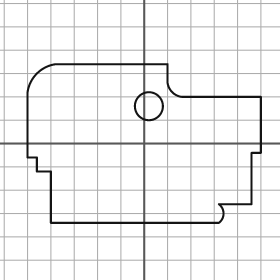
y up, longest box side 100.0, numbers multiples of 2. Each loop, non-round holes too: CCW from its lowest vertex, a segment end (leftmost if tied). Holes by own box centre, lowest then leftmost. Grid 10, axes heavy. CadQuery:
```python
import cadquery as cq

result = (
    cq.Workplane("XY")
    .moveTo(-40.0, -34.0)
    .lineTo(32.0, -34.0)
    .threePointArc((34.0, -30.0), (32.0, -26.0))
    .lineTo(46.0, -26.0)
    .lineTo(46.0, -4.0)
    .lineTo(50.0, -4.0)
    .lineTo(50.0, 20.0)
    .lineTo(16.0, 20.0)
    .threePointArc((12.0, 22.0), (10.0, 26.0))
    .lineTo(10.0, 34.0)
    .lineTo(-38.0, 34.0)
    .threePointArc((-46.0, 30.0), (-50.0, 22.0))
    .lineTo(-50.0, -6.0)
    .lineTo(-46.0, -6.0)
    .lineTo(-46.0, -12.0)
    .lineTo(-40.0, -12.0)
    .close()
    .moveTo(2.0, 16.0)
    .circle(6.0)
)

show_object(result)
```